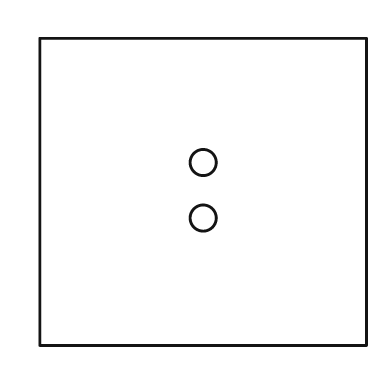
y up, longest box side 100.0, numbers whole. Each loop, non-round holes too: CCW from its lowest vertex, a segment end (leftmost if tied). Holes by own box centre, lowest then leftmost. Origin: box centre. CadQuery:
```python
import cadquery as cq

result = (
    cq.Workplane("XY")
    .moveTo(-50.0, -47.0)
    .lineTo(50.0, -47.0)
    .lineTo(50.0, 47.0)
    .lineTo(-50.0, 47.0)
    .close()
    .moveTo(0.0, -8.0)
    .circle(4.0)
    .moveTo(0.0, 9.0)
    .circle(4.0)
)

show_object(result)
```